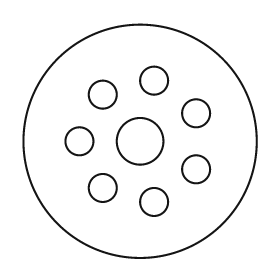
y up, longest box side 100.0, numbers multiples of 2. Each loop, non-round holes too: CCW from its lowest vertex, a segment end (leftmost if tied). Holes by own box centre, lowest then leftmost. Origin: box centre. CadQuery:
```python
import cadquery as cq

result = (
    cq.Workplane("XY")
    .moveTo(0.0, 0.0)
    .circle(50.0)
    .moveTo(6.0, -26.0)
    .circle(6.0)
    .moveTo(-16.0, -20.0)
    .circle(6.0)
    .moveTo(24.0, -12.0)
    .circle(6.0)
    .moveTo(-26.0, 0.0)
    .circle(6.0)
    .moveTo(0.0, 0.0)
    .circle(10.0)
    .moveTo(24.0, 12.0)
    .circle(6.0)
    .moveTo(-16.0, 20.0)
    .circle(6.0)
    .moveTo(6.0, 26.0)
    .circle(6.0)
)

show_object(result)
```